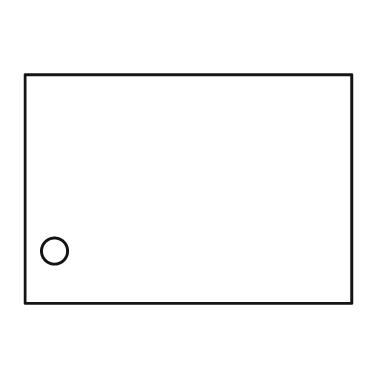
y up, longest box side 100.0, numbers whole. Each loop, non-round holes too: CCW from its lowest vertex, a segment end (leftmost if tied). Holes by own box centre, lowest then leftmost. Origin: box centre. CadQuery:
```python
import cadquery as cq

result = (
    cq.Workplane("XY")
    .moveTo(-50.0, -35.0)
    .lineTo(50.0, -35.0)
    .lineTo(50.0, 35.0)
    .lineTo(-50.0, 35.0)
    .close()
    .moveTo(-41.0, -19.0)
    .circle(4.0)
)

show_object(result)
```